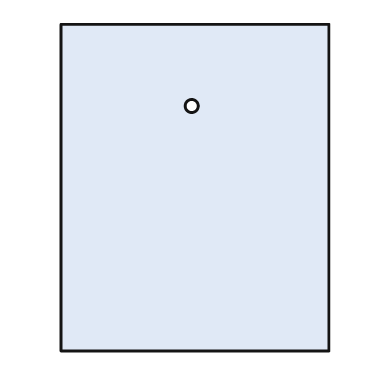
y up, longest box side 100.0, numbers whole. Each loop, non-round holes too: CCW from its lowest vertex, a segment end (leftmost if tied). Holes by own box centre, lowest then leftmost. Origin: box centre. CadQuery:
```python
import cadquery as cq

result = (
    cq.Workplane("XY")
    .moveTo(-41.0, -50.0)
    .lineTo(41.0, -50.0)
    .lineTo(41.0, 50.0)
    .lineTo(-41.0, 50.0)
    .close()
    .moveTo(-1.0, 25.0)
    .circle(2.0)
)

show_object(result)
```